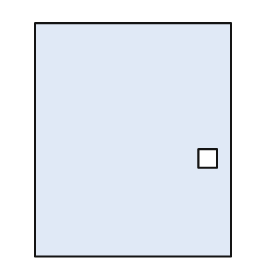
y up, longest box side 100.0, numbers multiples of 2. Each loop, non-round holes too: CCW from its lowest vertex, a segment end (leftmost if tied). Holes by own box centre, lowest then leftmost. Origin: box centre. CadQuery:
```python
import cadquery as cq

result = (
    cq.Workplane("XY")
    .moveTo(-42.0, -50.0)
    .lineTo(42.0, -50.0)
    .lineTo(42.0, 50.0)
    .lineTo(-42.0, 50.0)
    .close()
    .moveTo(28.0, -12.0)
    .lineTo(36.0, -12.0)
    .lineTo(36.0, -4.0)
    .lineTo(28.0, -4.0)
    .close()
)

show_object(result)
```